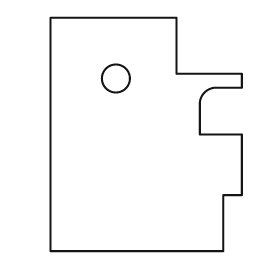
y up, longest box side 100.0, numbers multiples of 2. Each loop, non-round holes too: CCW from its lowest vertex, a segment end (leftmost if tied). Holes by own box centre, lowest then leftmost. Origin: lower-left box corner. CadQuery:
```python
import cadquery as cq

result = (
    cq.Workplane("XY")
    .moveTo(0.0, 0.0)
    .lineTo(74.0, 0.0)
    .lineTo(74.0, 24.0)
    .lineTo(82.0, 24.0)
    .lineTo(82.0, 50.0)
    .lineTo(64.0, 50.0)
    .lineTo(64.0, 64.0)
    .threePointArc((66.0, 68.0), (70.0, 70.0))
    .lineTo(82.0, 70.0)
    .lineTo(82.0, 76.0)
    .lineTo(54.0, 76.0)
    .lineTo(54.0, 100.0)
    .lineTo(0.0, 100.0)
    .close()
    .moveTo(28.0, 74.0)
    .circle(6.0)
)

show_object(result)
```